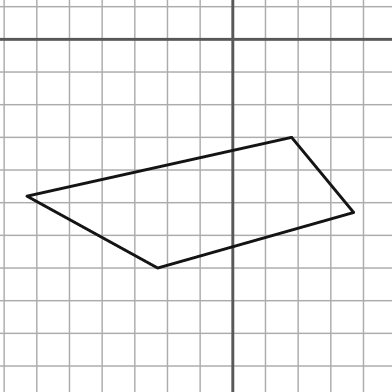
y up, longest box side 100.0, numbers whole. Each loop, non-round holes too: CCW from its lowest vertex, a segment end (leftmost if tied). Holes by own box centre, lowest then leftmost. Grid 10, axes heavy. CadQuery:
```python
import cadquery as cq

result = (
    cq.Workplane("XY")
    .moveTo(-23.0, -70.0)
    .lineTo(37.0, -53.0)
    .lineTo(18.0, -30.0)
    .lineTo(-63.0, -48.0)
    .close()
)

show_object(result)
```